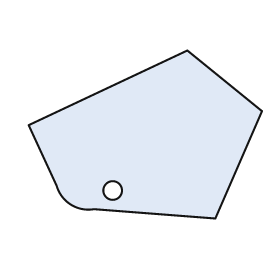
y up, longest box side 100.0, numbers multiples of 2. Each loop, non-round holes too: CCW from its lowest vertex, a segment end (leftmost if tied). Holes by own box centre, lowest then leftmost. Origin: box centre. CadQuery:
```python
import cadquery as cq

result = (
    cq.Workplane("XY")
    .moveTo(30.0, -36.0)
    .lineTo(50.0, 10.0)
    .lineTo(18.0, 36.0)
    .lineTo(-50.0, 4.0)
    .lineTo(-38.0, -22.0)
    .threePointArc((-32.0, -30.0), (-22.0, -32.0))
    .close()
    .moveTo(-14.0, -24.0)
    .circle(4.0)
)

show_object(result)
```